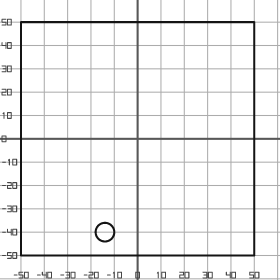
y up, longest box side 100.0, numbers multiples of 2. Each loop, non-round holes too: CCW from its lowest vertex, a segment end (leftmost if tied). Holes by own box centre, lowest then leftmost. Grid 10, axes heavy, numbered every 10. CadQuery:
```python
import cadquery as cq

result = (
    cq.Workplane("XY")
    .moveTo(-50.0, -50.0)
    .lineTo(50.0, -50.0)
    .lineTo(50.0, 50.0)
    .lineTo(-50.0, 50.0)
    .close()
    .moveTo(-14.0, -40.0)
    .circle(4.0)
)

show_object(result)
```